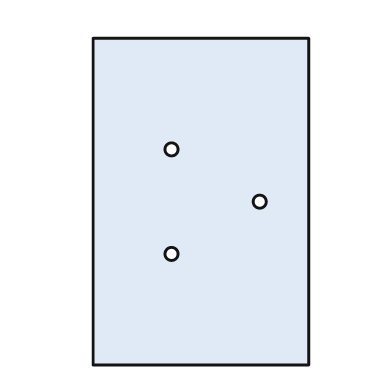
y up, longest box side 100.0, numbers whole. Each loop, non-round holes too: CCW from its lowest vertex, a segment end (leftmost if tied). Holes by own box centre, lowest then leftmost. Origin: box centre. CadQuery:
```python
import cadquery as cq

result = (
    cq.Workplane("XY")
    .moveTo(-33.0, -50.0)
    .lineTo(33.0, -50.0)
    .lineTo(33.0, 50.0)
    .lineTo(-33.0, 50.0)
    .close()
    .moveTo(-9.0, -16.0)
    .circle(2.0)
    .moveTo(18.0, 0.0)
    .circle(2.0)
    .moveTo(-9.0, 16.0)
    .circle(2.0)
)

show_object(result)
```